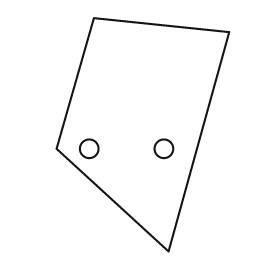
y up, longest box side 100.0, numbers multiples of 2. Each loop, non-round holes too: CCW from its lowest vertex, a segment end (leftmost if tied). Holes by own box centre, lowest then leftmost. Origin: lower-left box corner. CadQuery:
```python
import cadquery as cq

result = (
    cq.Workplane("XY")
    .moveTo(48.0, 0.0)
    .lineTo(74.0, 94.0)
    .lineTo(16.0, 100.0)
    .lineTo(0.0, 44.0)
    .close()
    .moveTo(14.0, 44.0)
    .circle(4.0)
    .moveTo(46.0, 44.0)
    .circle(4.0)
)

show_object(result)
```